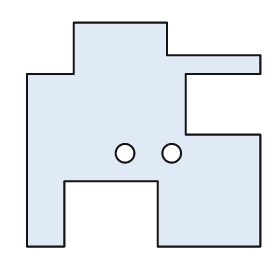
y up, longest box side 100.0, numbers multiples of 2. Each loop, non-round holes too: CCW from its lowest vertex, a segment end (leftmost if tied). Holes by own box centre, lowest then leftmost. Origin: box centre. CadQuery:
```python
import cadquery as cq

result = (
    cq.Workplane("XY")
    .moveTo(-50.0, -48.0)
    .lineTo(-34.0, -48.0)
    .lineTo(-34.0, -20.0)
    .lineTo(6.0, -20.0)
    .lineTo(6.0, -48.0)
    .lineTo(50.0, -48.0)
    .lineTo(50.0, 0.0)
    .lineTo(18.0, 0.0)
    .lineTo(18.0, 26.0)
    .lineTo(50.0, 26.0)
    .lineTo(50.0, 34.0)
    .lineTo(10.0, 34.0)
    .lineTo(10.0, 48.0)
    .lineTo(-30.0, 48.0)
    .lineTo(-30.0, 26.0)
    .lineTo(-50.0, 26.0)
    .close()
    .moveTo(-8.0, -8.0)
    .circle(4.0)
    .moveTo(12.0, -8.0)
    .circle(4.0)
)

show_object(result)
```